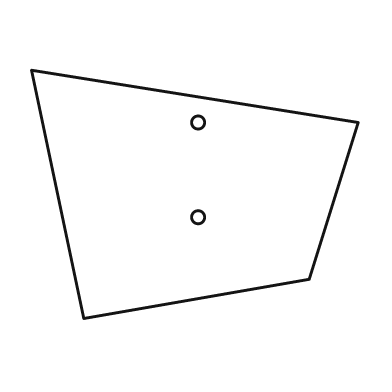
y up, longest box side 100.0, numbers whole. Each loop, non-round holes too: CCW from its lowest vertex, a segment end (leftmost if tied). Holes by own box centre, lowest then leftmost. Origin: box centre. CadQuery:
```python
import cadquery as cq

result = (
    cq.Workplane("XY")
    .moveTo(-34.0, -38.0)
    .lineTo(35.0, -26.0)
    .lineTo(50.0, 22.0)
    .lineTo(-50.0, 38.0)
    .close()
    .moveTo(1.0, -7.0)
    .circle(2.0)
    .moveTo(1.0, 22.0)
    .circle(2.0)
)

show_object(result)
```